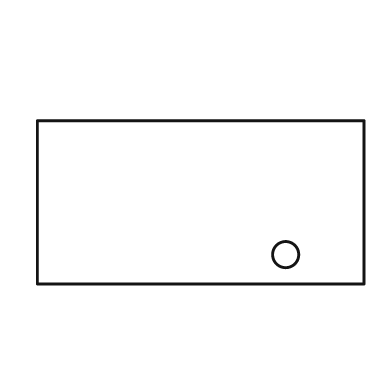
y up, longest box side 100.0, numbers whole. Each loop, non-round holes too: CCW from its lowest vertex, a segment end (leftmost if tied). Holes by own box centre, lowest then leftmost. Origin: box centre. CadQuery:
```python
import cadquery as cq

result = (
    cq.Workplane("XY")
    .moveTo(-50.0, -25.0)
    .lineTo(50.0, -25.0)
    .lineTo(50.0, 25.0)
    .lineTo(-50.0, 25.0)
    .close()
    .moveTo(26.0, -16.0)
    .circle(4.0)
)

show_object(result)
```